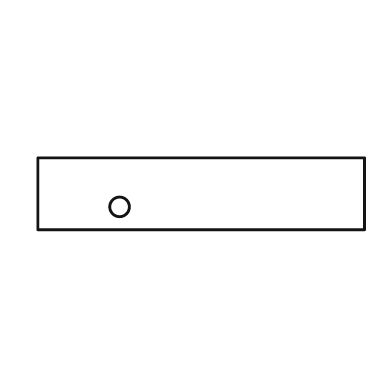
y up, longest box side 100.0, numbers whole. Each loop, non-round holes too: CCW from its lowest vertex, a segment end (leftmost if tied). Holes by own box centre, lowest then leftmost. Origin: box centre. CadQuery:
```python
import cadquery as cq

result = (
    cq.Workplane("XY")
    .moveTo(-50.0, -11.0)
    .lineTo(50.0, -11.0)
    .lineTo(50.0, 11.0)
    .lineTo(-50.0, 11.0)
    .close()
    .moveTo(-25.0, -4.0)
    .circle(3.0)
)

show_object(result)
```